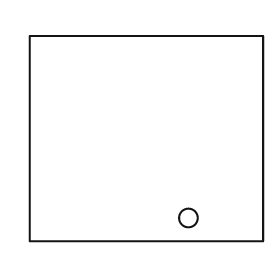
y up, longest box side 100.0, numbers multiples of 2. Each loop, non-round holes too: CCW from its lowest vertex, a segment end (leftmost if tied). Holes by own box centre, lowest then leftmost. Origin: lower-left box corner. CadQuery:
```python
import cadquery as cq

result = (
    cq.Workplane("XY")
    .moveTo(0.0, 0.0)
    .lineTo(100.0, 0.0)
    .lineTo(100.0, 88.0)
    .lineTo(0.0, 88.0)
    .close()
    .moveTo(68.0, 10.0)
    .circle(4.0)
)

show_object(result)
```